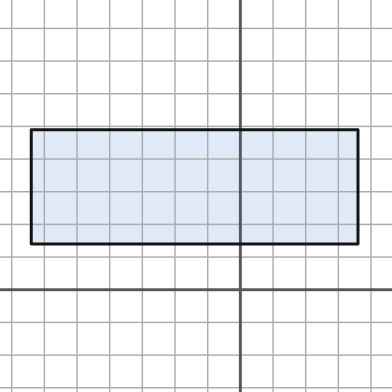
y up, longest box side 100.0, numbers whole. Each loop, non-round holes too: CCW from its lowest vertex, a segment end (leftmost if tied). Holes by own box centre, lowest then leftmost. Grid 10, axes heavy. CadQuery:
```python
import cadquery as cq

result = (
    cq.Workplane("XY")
    .moveTo(-64.0, 14.0)
    .lineTo(36.0, 14.0)
    .lineTo(36.0, 49.0)
    .lineTo(-64.0, 49.0)
    .close()
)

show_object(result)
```